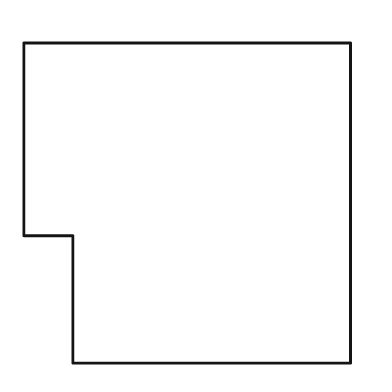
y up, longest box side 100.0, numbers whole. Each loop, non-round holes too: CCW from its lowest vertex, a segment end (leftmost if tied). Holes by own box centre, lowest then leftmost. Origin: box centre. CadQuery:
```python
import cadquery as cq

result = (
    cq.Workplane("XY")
    .moveTo(-35.0, -49.0)
    .lineTo(50.0, -49.0)
    .lineTo(50.0, 49.0)
    .lineTo(-50.0, 49.0)
    .lineTo(-50.0, -10.0)
    .lineTo(-35.0, -10.0)
    .close()
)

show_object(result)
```